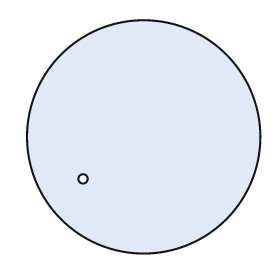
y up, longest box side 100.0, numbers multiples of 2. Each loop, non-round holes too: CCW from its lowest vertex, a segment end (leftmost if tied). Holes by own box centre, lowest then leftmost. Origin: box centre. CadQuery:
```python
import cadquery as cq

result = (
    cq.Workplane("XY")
    .moveTo(0.0, 0.0)
    .circle(50.0)
    .moveTo(-26.0, -18.0)
    .circle(2.0)
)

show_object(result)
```